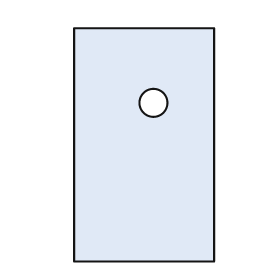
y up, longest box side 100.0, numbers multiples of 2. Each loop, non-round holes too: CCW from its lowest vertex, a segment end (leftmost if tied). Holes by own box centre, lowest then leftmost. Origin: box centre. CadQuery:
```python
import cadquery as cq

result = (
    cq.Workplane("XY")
    .moveTo(-30.0, -50.0)
    .lineTo(30.0, -50.0)
    .lineTo(30.0, 50.0)
    .lineTo(-30.0, 50.0)
    .close()
    .moveTo(4.0, 18.0)
    .circle(6.0)
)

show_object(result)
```